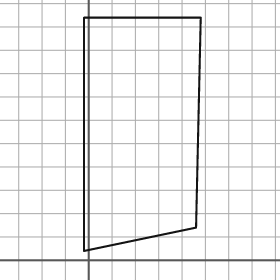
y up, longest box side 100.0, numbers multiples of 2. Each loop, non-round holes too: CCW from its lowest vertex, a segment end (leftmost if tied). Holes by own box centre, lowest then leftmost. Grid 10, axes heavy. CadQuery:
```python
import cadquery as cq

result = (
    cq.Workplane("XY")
    .moveTo(-2.0, 4.0)
    .lineTo(46.0, 14.0)
    .lineTo(48.0, 104.0)
    .lineTo(-2.0, 104.0)
    .close()
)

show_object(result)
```